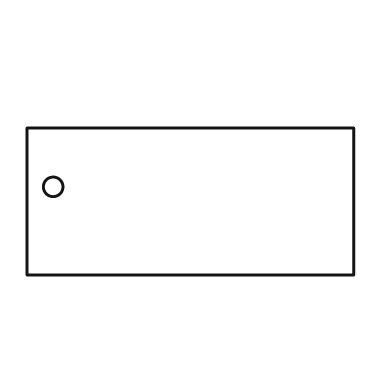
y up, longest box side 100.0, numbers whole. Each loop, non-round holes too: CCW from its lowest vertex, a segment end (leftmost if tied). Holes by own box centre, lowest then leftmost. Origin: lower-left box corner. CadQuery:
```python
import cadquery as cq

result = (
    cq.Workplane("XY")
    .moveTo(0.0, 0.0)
    .lineTo(100.0, 0.0)
    .lineTo(100.0, 45.0)
    .lineTo(0.0, 45.0)
    .close()
    .moveTo(8.0, 27.0)
    .circle(3.0)
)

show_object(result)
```